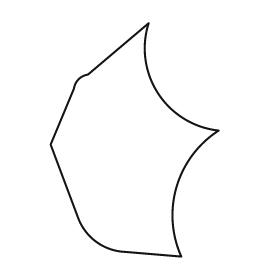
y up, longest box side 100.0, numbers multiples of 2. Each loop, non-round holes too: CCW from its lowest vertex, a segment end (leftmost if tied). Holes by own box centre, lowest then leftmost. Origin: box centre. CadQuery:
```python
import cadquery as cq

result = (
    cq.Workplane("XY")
    .moveTo(20.0, -50.0)
    .threePointArc((18.0, -20.0), (36.0, 4.0))
    .threePointArc((10.0, 20.0), (6.0, 50.0))
    .lineTo(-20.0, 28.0)
    .threePointArc((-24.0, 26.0), (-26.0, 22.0))
    .lineTo(-36.0, -2.0)
    .lineTo(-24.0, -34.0)
    .threePointArc((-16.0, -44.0), (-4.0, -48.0))
    .close()
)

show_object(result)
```